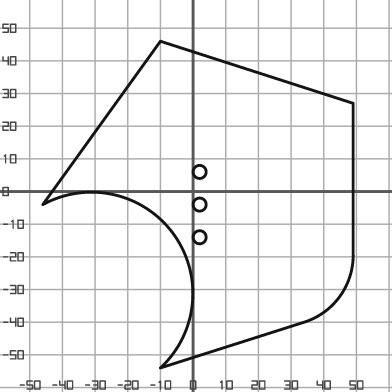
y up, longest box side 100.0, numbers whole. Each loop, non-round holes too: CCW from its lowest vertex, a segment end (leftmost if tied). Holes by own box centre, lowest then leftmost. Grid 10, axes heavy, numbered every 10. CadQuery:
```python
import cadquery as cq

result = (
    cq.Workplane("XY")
    .moveTo(-10.0, -54.0)
    .lineTo(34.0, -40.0)
    .threePointArc((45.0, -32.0), (49.0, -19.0))
    .lineTo(49.0, 27.0)
    .lineTo(-10.0, 46.0)
    .lineTo(-46.0, -4.0)
    .threePointArc((-6.0, -13.0), (-10.0, -54.0))
    .close()
    .moveTo(2.0, -14.0)
    .circle(2.0)
    .moveTo(2.0, -4.0)
    .circle(2.0)
    .moveTo(2.0, 6.0)
    .circle(2.0)
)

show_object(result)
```